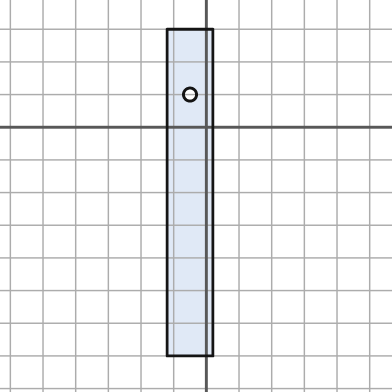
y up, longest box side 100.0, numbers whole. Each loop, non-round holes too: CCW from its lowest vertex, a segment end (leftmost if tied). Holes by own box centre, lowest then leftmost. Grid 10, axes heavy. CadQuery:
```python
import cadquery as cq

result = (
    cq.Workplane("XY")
    .moveTo(-12.0, -70.0)
    .lineTo(2.0, -70.0)
    .lineTo(2.0, 30.0)
    .lineTo(-12.0, 30.0)
    .close()
    .moveTo(-5.0, 10.0)
    .circle(2.0)
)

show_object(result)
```